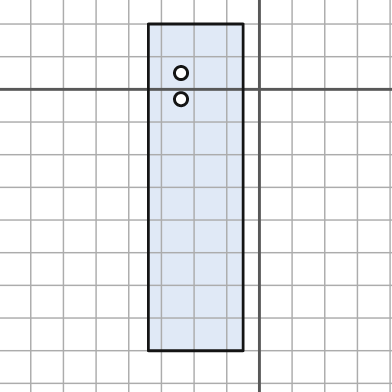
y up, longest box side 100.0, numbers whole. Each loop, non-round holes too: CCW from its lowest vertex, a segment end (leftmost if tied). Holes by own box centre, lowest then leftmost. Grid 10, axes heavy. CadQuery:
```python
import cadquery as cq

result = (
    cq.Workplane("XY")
    .moveTo(-34.0, -80.0)
    .lineTo(-5.0, -80.0)
    .lineTo(-5.0, 20.0)
    .lineTo(-34.0, 20.0)
    .close()
    .moveTo(-24.0, -3.0)
    .circle(2.0)
    .moveTo(-24.0, 5.0)
    .circle(2.0)
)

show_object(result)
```